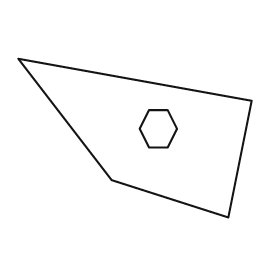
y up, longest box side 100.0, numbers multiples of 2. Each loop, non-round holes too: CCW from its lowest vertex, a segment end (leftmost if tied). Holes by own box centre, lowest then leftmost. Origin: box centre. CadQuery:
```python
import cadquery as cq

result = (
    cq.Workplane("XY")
    .moveTo(40.0, -34.0)
    .lineTo(50.0, 16.0)
    .lineTo(-50.0, 34.0)
    .lineTo(-10.0, -18.0)
    .close()
    .moveTo(6.0, -4.0)
    .lineTo(14.0, -4.0)
    .lineTo(18.0, 4.0)
    .lineTo(14.0, 12.0)
    .lineTo(6.0, 12.0)
    .lineTo(2.0, 4.0)
    .close()
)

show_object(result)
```